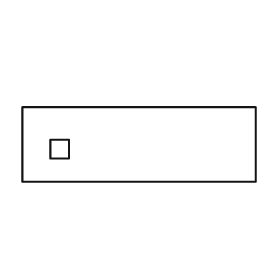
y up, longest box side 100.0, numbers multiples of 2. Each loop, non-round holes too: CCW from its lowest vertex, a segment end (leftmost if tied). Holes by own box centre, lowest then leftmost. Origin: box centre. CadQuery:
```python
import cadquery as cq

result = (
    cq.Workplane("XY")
    .moveTo(-50.0, -16.0)
    .lineTo(50.0, -16.0)
    .lineTo(50.0, 16.0)
    .lineTo(-50.0, 16.0)
    .close()
    .moveTo(-38.0, -6.0)
    .lineTo(-30.0, -6.0)
    .lineTo(-30.0, 2.0)
    .lineTo(-38.0, 2.0)
    .close()
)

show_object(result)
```